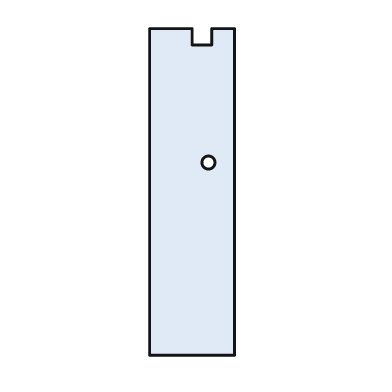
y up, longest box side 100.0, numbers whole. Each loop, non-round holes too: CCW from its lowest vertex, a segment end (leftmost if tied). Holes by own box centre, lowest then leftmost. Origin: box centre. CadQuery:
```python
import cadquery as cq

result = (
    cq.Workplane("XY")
    .moveTo(-13.0, -50.0)
    .lineTo(13.0, -50.0)
    .lineTo(13.0, 50.0)
    .lineTo(6.0, 50.0)
    .lineTo(6.0, 45.0)
    .lineTo(0.0, 45.0)
    .lineTo(0.0, 50.0)
    .lineTo(-13.0, 50.0)
    .close()
    .moveTo(5.0, 9.0)
    .circle(2.0)
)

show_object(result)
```